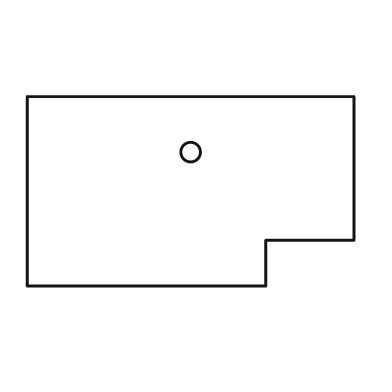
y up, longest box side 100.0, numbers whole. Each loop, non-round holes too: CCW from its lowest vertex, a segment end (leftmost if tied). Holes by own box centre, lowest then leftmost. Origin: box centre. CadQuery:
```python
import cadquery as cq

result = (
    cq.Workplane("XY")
    .moveTo(-50.0, -29.0)
    .lineTo(23.0, -29.0)
    .lineTo(23.0, -15.0)
    .lineTo(50.0, -15.0)
    .lineTo(50.0, 29.0)
    .lineTo(-50.0, 29.0)
    .close()
    .moveTo(0.0, 12.0)
    .circle(3.0)
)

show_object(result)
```